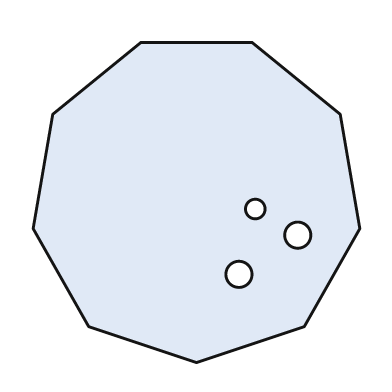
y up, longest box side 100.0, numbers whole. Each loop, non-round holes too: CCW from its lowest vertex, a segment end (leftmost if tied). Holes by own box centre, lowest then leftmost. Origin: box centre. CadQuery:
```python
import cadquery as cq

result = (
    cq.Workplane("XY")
    .moveTo(0.0, -49.0)
    .lineTo(33.0, -38.0)
    .lineTo(50.0, -8.0)
    .lineTo(44.0, 27.0)
    .lineTo(17.0, 49.0)
    .lineTo(-17.0, 49.0)
    .lineTo(-44.0, 27.0)
    .lineTo(-50.0, -8.0)
    .lineTo(-33.0, -38.0)
    .close()
    .moveTo(13.0, -22.0)
    .circle(4.0)
    .moveTo(31.0, -10.0)
    .circle(4.0)
    .moveTo(18.0, -2.0)
    .circle(3.0)
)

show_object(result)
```